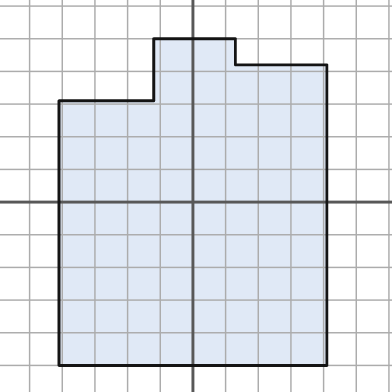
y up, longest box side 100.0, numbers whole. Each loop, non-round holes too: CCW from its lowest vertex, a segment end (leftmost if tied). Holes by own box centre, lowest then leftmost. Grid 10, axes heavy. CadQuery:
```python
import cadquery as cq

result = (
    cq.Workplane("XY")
    .moveTo(-41.0, -50.0)
    .lineTo(41.0, -50.0)
    .lineTo(41.0, 42.0)
    .lineTo(13.0, 42.0)
    .lineTo(13.0, 50.0)
    .lineTo(-12.0, 50.0)
    .lineTo(-12.0, 31.0)
    .lineTo(-41.0, 31.0)
    .close()
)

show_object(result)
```